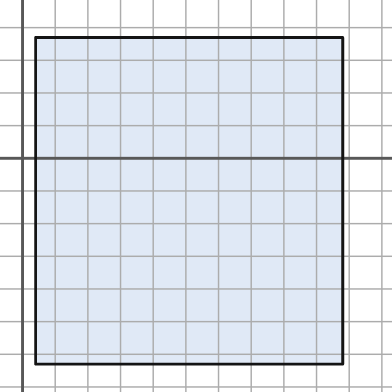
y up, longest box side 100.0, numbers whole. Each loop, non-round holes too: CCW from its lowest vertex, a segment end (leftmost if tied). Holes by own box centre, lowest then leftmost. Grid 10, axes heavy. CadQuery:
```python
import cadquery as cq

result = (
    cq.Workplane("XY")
    .moveTo(4.0, -63.0)
    .lineTo(98.0, -63.0)
    .lineTo(98.0, 37.0)
    .lineTo(4.0, 37.0)
    .close()
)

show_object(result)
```